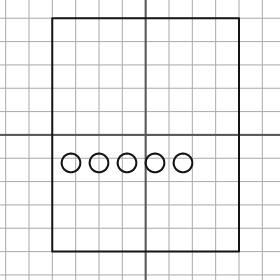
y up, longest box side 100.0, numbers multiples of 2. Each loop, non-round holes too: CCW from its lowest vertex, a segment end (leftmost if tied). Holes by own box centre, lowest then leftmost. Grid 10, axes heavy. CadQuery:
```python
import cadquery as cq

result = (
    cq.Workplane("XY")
    .moveTo(-40.0, -50.0)
    .lineTo(40.0, -50.0)
    .lineTo(40.0, 50.0)
    .lineTo(-40.0, 50.0)
    .close()
    .moveTo(-32.0, -12.0)
    .circle(4.0)
    .moveTo(-20.0, -12.0)
    .circle(4.0)
    .moveTo(-8.0, -12.0)
    .circle(4.0)
    .moveTo(4.0, -12.0)
    .circle(4.0)
    .moveTo(16.0, -12.0)
    .circle(4.0)
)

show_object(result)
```